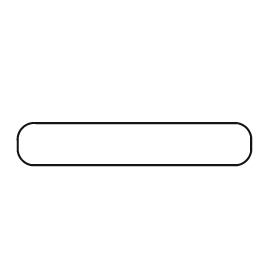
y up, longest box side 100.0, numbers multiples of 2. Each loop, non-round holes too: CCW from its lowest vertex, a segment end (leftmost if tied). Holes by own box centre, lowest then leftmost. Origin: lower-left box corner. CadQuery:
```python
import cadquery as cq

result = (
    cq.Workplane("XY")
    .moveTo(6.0, 0.0)
    .lineTo(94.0, 0.0)
    .threePointArc((98.0, 2.0), (100.0, 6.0))
    .lineTo(100.0, 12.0)
    .threePointArc((98.0, 16.0), (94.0, 18.0))
    .lineTo(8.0, 18.0)
    .threePointArc((2.0, 16.0), (0.0, 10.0))
    .lineTo(0.0, 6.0)
    .threePointArc((2.0, 2.0), (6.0, 0.0))
    .close()
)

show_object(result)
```